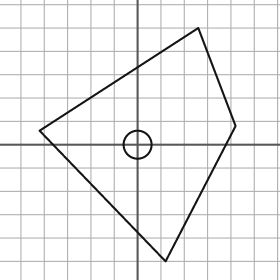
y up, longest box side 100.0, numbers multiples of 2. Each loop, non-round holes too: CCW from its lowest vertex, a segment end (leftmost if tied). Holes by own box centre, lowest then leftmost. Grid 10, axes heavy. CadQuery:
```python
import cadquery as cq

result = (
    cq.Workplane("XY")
    .moveTo(12.0, -50.0)
    .lineTo(42.0, 8.0)
    .lineTo(26.0, 50.0)
    .lineTo(-42.0, 6.0)
    .close()
    .moveTo(0.0, 0.0)
    .circle(6.0)
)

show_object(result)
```